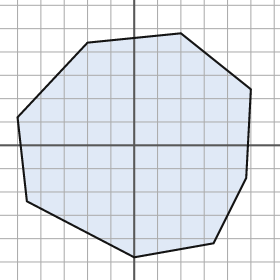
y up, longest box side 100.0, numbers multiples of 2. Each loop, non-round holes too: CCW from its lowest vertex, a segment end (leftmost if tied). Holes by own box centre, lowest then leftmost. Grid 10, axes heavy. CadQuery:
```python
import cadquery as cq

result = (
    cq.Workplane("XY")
    .moveTo(0.0, -48.0)
    .lineTo(34.0, -42.0)
    .lineTo(48.0, -14.0)
    .lineTo(50.0, 24.0)
    .lineTo(20.0, 48.0)
    .lineTo(-20.0, 44.0)
    .lineTo(-50.0, 12.0)
    .lineTo(-46.0, -24.0)
    .close()
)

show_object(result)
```